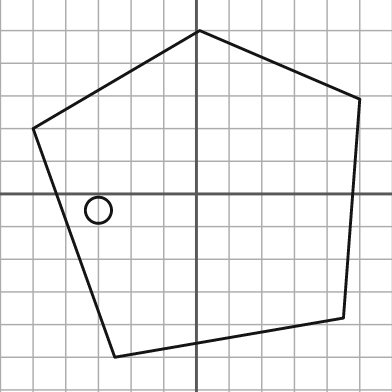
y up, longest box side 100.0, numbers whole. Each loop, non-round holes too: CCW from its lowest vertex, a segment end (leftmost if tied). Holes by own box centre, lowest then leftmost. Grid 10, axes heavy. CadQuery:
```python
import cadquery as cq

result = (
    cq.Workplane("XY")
    .moveTo(-25.0, -50.0)
    .lineTo(45.0, -38.0)
    .lineTo(50.0, 29.0)
    .lineTo(1.0, 50.0)
    .lineTo(-50.0, 20.0)
    .close()
    .moveTo(-30.0, -5.0)
    .circle(4.0)
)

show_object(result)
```